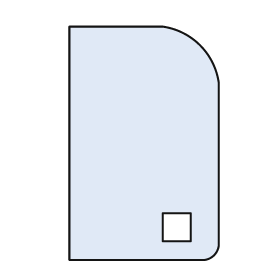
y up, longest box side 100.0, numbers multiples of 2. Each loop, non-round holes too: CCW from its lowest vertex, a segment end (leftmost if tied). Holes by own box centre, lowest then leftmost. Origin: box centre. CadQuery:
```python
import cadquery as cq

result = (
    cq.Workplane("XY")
    .moveTo(-32.0, -50.0)
    .lineTo(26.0, -50.0)
    .threePointArc((30.0, -48.0), (32.0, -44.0))
    .lineTo(32.0, 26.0)
    .threePointArc((24.0, 42.0), (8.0, 50.0))
    .lineTo(-32.0, 50.0)
    .close()
    .moveTo(8.0, -42.0)
    .lineTo(20.0, -42.0)
    .lineTo(20.0, -30.0)
    .lineTo(8.0, -30.0)
    .close()
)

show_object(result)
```